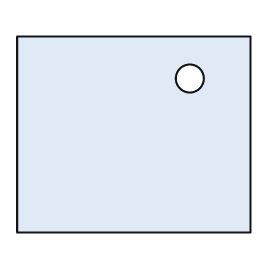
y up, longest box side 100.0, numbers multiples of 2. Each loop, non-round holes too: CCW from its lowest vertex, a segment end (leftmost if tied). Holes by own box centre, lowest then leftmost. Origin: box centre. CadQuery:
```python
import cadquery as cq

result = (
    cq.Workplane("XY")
    .moveTo(-50.0, -42.0)
    .lineTo(50.0, -42.0)
    .lineTo(50.0, 42.0)
    .lineTo(-50.0, 42.0)
    .close()
    .moveTo(24.0, 24.0)
    .circle(6.0)
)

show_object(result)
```